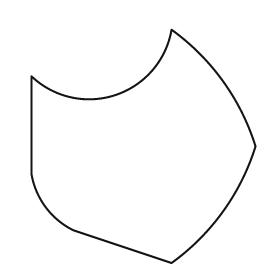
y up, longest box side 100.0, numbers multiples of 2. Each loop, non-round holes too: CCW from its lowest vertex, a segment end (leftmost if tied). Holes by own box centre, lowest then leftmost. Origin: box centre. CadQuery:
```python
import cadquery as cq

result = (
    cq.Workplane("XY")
    .moveTo(12.0, -50.0)
    .threePointArc((34.0, -28.0), (48.0, 0.0))
    .threePointArc((34.0, 28.0), (12.0, 50.0))
    .threePointArc((-12.0, 22.0), (-48.0, 30.0))
    .lineTo(-48.0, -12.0)
    .threePointArc((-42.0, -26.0), (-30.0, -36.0))
    .close()
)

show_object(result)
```